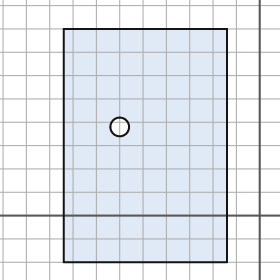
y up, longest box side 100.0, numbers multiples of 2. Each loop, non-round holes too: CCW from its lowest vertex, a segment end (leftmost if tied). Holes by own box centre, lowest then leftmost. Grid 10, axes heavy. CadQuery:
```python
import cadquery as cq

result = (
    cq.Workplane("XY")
    .moveTo(-84.0, -20.0)
    .lineTo(-14.0, -20.0)
    .lineTo(-14.0, 80.0)
    .lineTo(-84.0, 80.0)
    .close()
    .moveTo(-60.0, 38.0)
    .circle(4.0)
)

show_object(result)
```